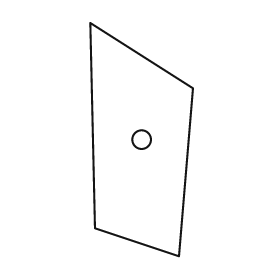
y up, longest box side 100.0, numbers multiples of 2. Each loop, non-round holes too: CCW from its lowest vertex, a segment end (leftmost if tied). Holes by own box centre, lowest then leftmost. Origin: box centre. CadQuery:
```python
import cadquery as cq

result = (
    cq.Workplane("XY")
    .moveTo(16.0, -50.0)
    .lineTo(22.0, 22.0)
    .lineTo(-22.0, 50.0)
    .lineTo(-20.0, -38.0)
    .close()
    .moveTo(0.0, 0.0)
    .circle(4.0)
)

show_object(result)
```